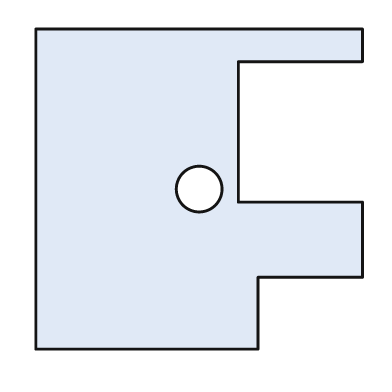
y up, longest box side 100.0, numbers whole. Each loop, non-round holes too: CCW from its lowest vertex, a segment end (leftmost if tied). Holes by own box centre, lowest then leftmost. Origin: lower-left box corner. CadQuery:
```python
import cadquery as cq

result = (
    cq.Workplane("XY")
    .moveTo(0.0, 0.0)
    .lineTo(68.0, 0.0)
    .lineTo(68.0, 22.0)
    .lineTo(100.0, 22.0)
    .lineTo(100.0, 45.0)
    .lineTo(62.0, 45.0)
    .lineTo(62.0, 88.0)
    .lineTo(100.0, 88.0)
    .lineTo(100.0, 98.0)
    .lineTo(0.0, 98.0)
    .close()
    .moveTo(50.0, 49.0)
    .circle(7.0)
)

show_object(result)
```